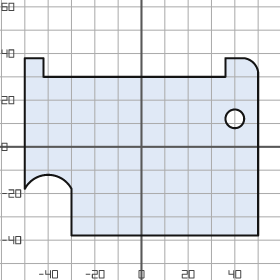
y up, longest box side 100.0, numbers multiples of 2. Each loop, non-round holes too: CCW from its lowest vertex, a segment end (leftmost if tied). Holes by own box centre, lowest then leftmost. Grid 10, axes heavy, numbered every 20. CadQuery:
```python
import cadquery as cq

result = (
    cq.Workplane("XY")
    .moveTo(-30.0, -38.0)
    .lineTo(50.0, -38.0)
    .lineTo(50.0, 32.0)
    .threePointArc((48.0, 36.0), (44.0, 38.0))
    .lineTo(36.0, 38.0)
    .lineTo(36.0, 30.0)
    .lineTo(-42.0, 30.0)
    .lineTo(-42.0, 38.0)
    .lineTo(-50.0, 38.0)
    .lineTo(-50.0, -18.0)
    .threePointArc((-40.0, -12.0), (-30.0, -18.0))
    .close()
    .moveTo(40.0, 12.0)
    .circle(4.0)
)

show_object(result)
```